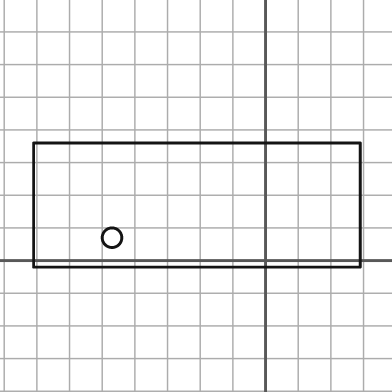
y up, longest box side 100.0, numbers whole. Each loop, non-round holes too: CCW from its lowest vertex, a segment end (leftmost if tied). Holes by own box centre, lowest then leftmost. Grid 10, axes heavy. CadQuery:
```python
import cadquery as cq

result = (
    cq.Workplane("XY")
    .moveTo(-71.0, -2.0)
    .lineTo(29.0, -2.0)
    .lineTo(29.0, 36.0)
    .lineTo(-71.0, 36.0)
    .close()
    .moveTo(-47.0, 7.0)
    .circle(3.0)
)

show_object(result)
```